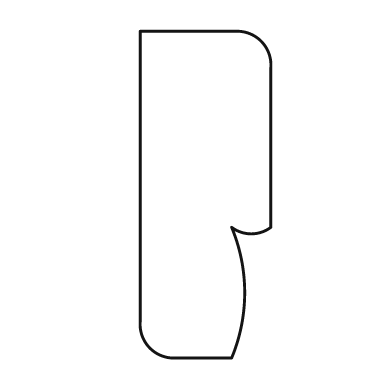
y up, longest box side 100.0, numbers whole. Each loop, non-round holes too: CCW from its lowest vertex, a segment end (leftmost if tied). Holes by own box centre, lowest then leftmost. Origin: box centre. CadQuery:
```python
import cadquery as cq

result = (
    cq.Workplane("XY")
    .moveTo(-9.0, -50.0)
    .lineTo(8.0, -50.0)
    .threePointArc((12.0, -30.0), (8.0, -10.0))
    .threePointArc((14.0, -12.0), (20.0, -10.0))
    .lineTo(20.0, 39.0)
    .threePointArc((17.0, 47.0), (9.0, 50.0))
    .lineTo(-20.0, 50.0)
    .lineTo(-20.0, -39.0)
    .threePointArc((-17.0, -47.0), (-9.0, -50.0))
    .close()
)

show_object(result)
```